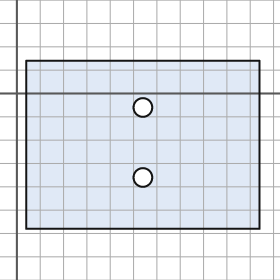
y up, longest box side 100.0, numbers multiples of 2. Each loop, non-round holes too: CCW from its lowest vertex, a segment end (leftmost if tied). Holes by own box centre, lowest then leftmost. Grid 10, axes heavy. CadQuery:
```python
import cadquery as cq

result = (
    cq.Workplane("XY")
    .moveTo(4.0, -58.0)
    .lineTo(104.0, -58.0)
    .lineTo(104.0, 14.0)
    .lineTo(4.0, 14.0)
    .close()
    .moveTo(54.0, -36.0)
    .circle(4.0)
    .moveTo(54.0, -6.0)
    .circle(4.0)
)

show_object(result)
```